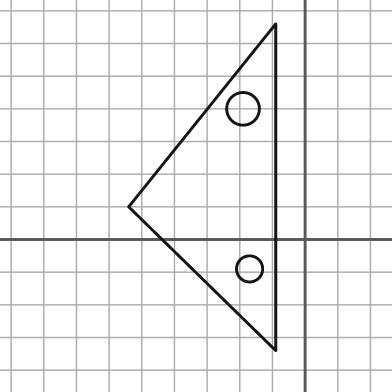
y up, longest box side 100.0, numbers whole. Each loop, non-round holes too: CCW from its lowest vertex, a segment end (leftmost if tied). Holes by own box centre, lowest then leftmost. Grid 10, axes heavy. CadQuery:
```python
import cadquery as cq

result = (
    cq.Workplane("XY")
    .moveTo(-9.0, -34.0)
    .lineTo(-9.0, 66.0)
    .lineTo(-54.0, 10.0)
    .close()
    .moveTo(-17.0, -9.0)
    .circle(4.0)
    .moveTo(-19.0, 40.0)
    .circle(5.0)
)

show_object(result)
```